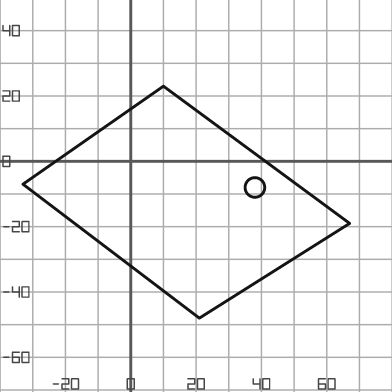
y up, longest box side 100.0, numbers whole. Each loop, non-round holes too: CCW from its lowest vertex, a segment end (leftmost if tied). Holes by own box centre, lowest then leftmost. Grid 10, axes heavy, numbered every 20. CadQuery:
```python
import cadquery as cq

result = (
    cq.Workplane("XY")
    .moveTo(21.0, -48.0)
    .lineTo(67.0, -19.0)
    .lineTo(10.0, 23.0)
    .lineTo(-33.0, -7.0)
    .close()
    .moveTo(38.0, -8.0)
    .circle(3.0)
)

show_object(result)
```